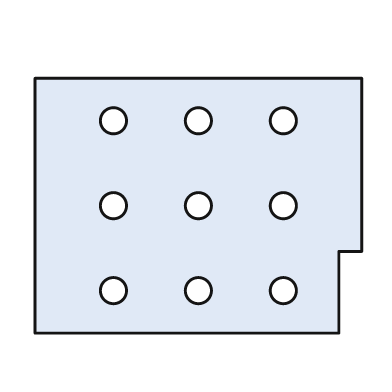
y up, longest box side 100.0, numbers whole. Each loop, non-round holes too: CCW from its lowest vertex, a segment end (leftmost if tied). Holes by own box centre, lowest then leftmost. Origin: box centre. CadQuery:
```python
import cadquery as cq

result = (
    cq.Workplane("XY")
    .moveTo(-50.0, -39.0)
    .lineTo(43.0, -39.0)
    .lineTo(43.0, -14.0)
    .lineTo(50.0, -14.0)
    .lineTo(50.0, 39.0)
    .lineTo(-50.0, 39.0)
    .close()
    .moveTo(-26.0, -26.0)
    .circle(4.0)
    .moveTo(0.0, -26.0)
    .circle(4.0)
    .moveTo(26.0, -26.0)
    .circle(4.0)
    .moveTo(-26.0, 0.0)
    .circle(4.0)
    .moveTo(0.0, 0.0)
    .circle(4.0)
    .moveTo(26.0, 0.0)
    .circle(4.0)
    .moveTo(-26.0, 26.0)
    .circle(4.0)
    .moveTo(0.0, 26.0)
    .circle(4.0)
    .moveTo(26.0, 26.0)
    .circle(4.0)
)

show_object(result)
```